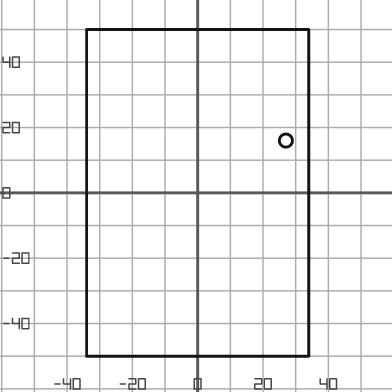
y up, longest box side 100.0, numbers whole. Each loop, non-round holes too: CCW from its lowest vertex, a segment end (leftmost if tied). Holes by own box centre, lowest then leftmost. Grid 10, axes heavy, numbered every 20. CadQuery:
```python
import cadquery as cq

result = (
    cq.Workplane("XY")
    .moveTo(-34.0, -50.0)
    .lineTo(34.0, -50.0)
    .lineTo(34.0, 50.0)
    .lineTo(-34.0, 50.0)
    .close()
    .moveTo(27.0, 16.0)
    .circle(2.0)
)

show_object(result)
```